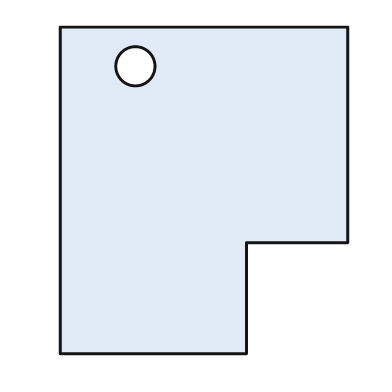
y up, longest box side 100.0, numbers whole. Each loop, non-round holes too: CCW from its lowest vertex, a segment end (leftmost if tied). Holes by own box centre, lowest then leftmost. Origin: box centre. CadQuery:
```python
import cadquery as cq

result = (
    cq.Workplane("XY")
    .moveTo(-44.0, -50.0)
    .lineTo(13.0, -50.0)
    .lineTo(13.0, -16.0)
    .lineTo(44.0, -16.0)
    .lineTo(44.0, 50.0)
    .lineTo(-44.0, 50.0)
    .close()
    .moveTo(-21.0, 38.0)
    .circle(6.0)
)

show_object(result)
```